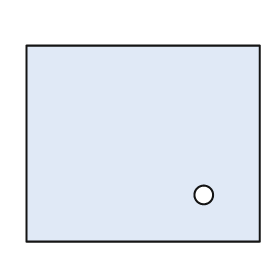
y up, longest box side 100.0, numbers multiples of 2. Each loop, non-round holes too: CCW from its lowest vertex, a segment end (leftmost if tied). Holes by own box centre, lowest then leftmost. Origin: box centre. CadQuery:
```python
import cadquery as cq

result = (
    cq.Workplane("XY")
    .moveTo(-50.0, -42.0)
    .lineTo(50.0, -42.0)
    .lineTo(50.0, 42.0)
    .lineTo(-50.0, 42.0)
    .close()
    .moveTo(26.0, -22.0)
    .circle(4.0)
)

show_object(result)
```